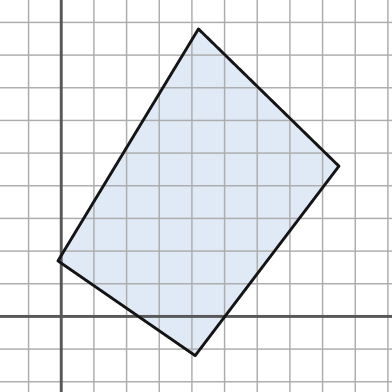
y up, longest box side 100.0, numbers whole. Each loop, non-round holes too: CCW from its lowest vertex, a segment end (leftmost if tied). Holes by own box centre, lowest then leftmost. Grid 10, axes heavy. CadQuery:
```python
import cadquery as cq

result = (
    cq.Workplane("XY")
    .moveTo(41.0, -12.0)
    .lineTo(85.0, 46.0)
    .lineTo(42.0, 88.0)
    .lineTo(-1.0, 17.0)
    .close()
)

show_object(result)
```